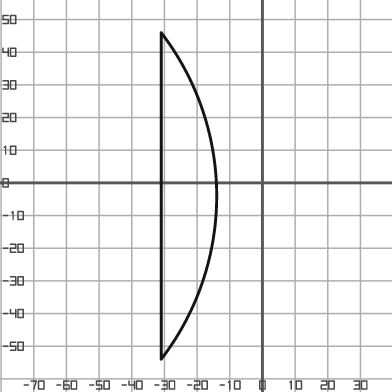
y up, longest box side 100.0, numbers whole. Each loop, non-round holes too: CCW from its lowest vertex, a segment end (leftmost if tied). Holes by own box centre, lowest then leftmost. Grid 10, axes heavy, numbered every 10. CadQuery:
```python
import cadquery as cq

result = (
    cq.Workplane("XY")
    .moveTo(-31.0, -54.0)
    .threePointArc((-14.0, -4.0), (-31.0, 46.0))
    .close()
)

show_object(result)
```